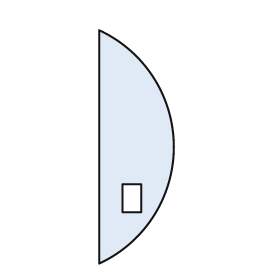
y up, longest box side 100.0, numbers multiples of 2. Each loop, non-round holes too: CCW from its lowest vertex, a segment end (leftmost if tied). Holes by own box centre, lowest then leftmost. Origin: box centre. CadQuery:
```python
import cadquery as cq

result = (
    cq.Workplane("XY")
    .moveTo(-16.0, -50.0)
    .threePointArc((16.0, 0.0), (-16.0, 50.0))
    .close()
    .moveTo(-6.0, -28.0)
    .lineTo(2.0, -28.0)
    .lineTo(2.0, -16.0)
    .lineTo(-6.0, -16.0)
    .close()
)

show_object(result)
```